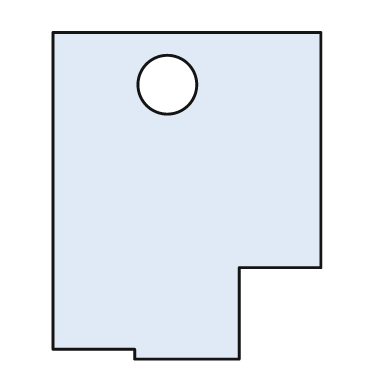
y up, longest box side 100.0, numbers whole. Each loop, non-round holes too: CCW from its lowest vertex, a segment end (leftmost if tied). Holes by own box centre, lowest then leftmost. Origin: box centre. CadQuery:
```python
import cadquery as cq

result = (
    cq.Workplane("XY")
    .moveTo(-16.0, -50.0)
    .lineTo(16.0, -50.0)
    .lineTo(16.0, -22.0)
    .lineTo(41.0, -22.0)
    .lineTo(41.0, 50.0)
    .lineTo(-41.0, 50.0)
    .lineTo(-41.0, -47.0)
    .lineTo(-16.0, -47.0)
    .close()
    .moveTo(-6.0, 34.0)
    .circle(9.0)
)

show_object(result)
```